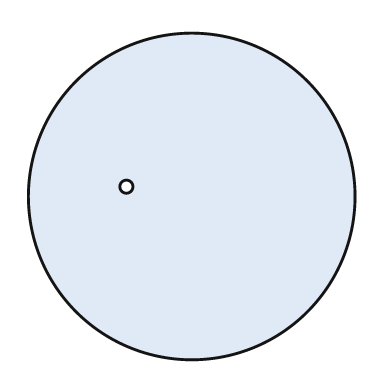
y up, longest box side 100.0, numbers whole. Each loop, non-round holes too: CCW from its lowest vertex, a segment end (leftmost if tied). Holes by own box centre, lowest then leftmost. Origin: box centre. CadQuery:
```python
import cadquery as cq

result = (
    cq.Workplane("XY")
    .moveTo(0.0, 0.0)
    .circle(50.0)
    .moveTo(-20.0, 3.0)
    .circle(2.0)
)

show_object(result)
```